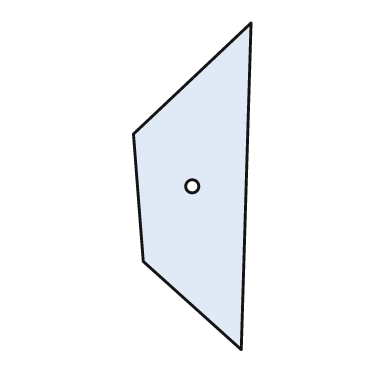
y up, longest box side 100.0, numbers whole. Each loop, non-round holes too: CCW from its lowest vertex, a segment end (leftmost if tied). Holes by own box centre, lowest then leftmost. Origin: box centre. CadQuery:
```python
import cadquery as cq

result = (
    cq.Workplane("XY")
    .moveTo(15.0, -50.0)
    .lineTo(18.0, 50.0)
    .lineTo(-18.0, 16.0)
    .lineTo(-15.0, -23.0)
    .close()
    .moveTo(0.0, 0.0)
    .circle(2.0)
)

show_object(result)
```